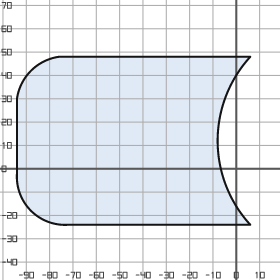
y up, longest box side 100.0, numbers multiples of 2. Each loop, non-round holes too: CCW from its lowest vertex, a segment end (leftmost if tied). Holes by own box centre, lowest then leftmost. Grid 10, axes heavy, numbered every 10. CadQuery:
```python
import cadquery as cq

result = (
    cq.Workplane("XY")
    .moveTo(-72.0, -24.0)
    .lineTo(6.0, -24.0)
    .threePointArc((-8.0, 12.0), (6.0, 48.0))
    .lineTo(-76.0, 48.0)
    .threePointArc((-88.0, 42.0), (-94.0, 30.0))
    .lineTo(-94.0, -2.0)
    .threePointArc((-88.0, -18.0), (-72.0, -24.0))
    .close()
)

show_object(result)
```